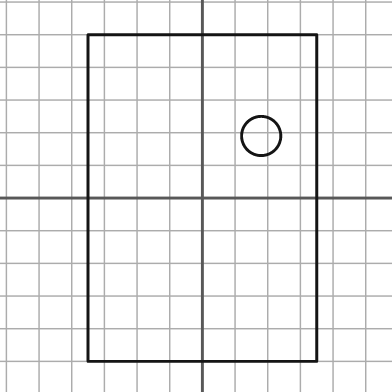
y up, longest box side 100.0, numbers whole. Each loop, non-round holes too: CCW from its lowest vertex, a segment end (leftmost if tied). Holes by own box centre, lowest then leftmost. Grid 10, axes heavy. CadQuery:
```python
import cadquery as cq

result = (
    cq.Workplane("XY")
    .moveTo(-35.0, -50.0)
    .lineTo(35.0, -50.0)
    .lineTo(35.0, 50.0)
    .lineTo(-35.0, 50.0)
    .close()
    .moveTo(18.0, 19.0)
    .circle(6.0)
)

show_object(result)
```